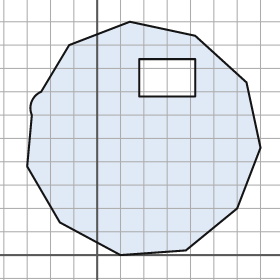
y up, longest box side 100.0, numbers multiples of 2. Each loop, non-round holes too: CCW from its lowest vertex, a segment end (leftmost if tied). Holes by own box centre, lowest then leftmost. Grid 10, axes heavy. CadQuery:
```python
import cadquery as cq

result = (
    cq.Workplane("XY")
    .moveTo(10.0, 0.0)
    .lineTo(38.0, 2.0)
    .lineTo(60.0, 20.0)
    .lineTo(70.0, 46.0)
    .lineTo(64.0, 74.0)
    .lineTo(42.0, 94.0)
    .lineTo(14.0, 100.0)
    .lineTo(-12.0, 90.0)
    .lineTo(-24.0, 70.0)
    .threePointArc((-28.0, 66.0), (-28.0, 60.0))
    .lineTo(-30.0, 38.0)
    .lineTo(-16.0, 14.0)
    .close()
    .moveTo(18.0, 68.0)
    .lineTo(42.0, 68.0)
    .lineTo(42.0, 84.0)
    .lineTo(18.0, 84.0)
    .close()
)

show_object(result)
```